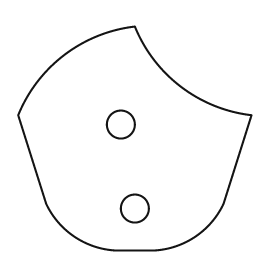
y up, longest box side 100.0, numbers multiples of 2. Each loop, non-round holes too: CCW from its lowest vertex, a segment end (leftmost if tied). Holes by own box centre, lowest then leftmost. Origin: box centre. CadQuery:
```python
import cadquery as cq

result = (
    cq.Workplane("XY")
    .moveTo(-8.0, -48.0)
    .lineTo(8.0, -48.0)
    .threePointArc((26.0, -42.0), (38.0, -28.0))
    .lineTo(50.0, 10.0)
    .threePointArc((20.0, 22.0), (0.0, 48.0))
    .threePointArc((-30.0, 36.0), (-50.0, 10.0))
    .lineTo(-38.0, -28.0)
    .threePointArc((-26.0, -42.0), (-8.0, -48.0))
    .close()
    .moveTo(0.0, -30.0)
    .circle(6.0)
    .moveTo(-6.0, 6.0)
    .circle(6.0)
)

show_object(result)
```